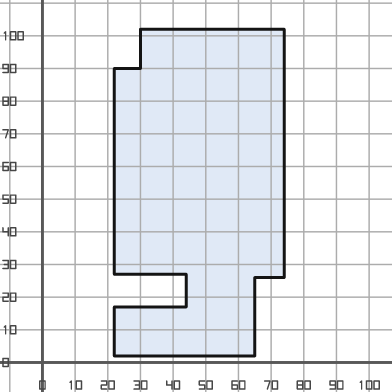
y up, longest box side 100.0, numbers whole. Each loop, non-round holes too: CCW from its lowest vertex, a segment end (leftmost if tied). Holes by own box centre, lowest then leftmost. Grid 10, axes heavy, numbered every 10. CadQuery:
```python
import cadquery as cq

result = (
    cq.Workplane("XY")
    .moveTo(22.0, 2.0)
    .lineTo(65.0, 2.0)
    .lineTo(65.0, 26.0)
    .lineTo(74.0, 26.0)
    .lineTo(74.0, 102.0)
    .lineTo(30.0, 102.0)
    .lineTo(30.0, 90.0)
    .lineTo(22.0, 90.0)
    .lineTo(22.0, 27.0)
    .lineTo(44.0, 27.0)
    .lineTo(44.0, 17.0)
    .lineTo(22.0, 17.0)
    .close()
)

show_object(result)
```